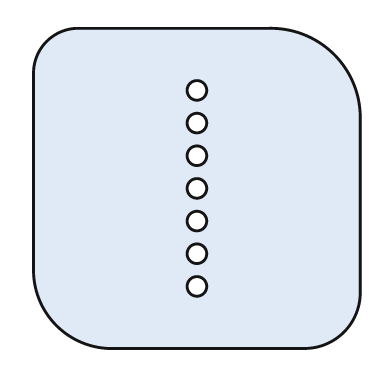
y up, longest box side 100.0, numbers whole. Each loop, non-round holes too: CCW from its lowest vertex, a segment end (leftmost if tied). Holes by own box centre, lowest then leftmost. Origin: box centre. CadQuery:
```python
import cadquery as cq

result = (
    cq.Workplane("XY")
    .moveTo(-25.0, -49.0)
    .lineTo(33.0, -49.0)
    .threePointArc((45.0, -44.0), (50.0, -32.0))
    .lineTo(50.0, 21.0)
    .threePointArc((42.0, 41.0), (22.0, 49.0))
    .lineTo(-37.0, 49.0)
    .threePointArc((-46.0, 45.0), (-50.0, 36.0))
    .lineTo(-50.0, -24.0)
    .threePointArc((-43.0, -42.0), (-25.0, -49.0))
    .close()
    .moveTo(0.0, -30.0)
    .circle(3.0)
    .moveTo(0.0, -20.0)
    .circle(3.0)
    .moveTo(0.0, -10.0)
    .circle(3.0)
    .moveTo(0.0, 0.0)
    .circle(3.0)
    .moveTo(0.0, 10.0)
    .circle(3.0)
    .moveTo(0.0, 20.0)
    .circle(3.0)
    .moveTo(0.0, 30.0)
    .circle(3.0)
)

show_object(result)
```